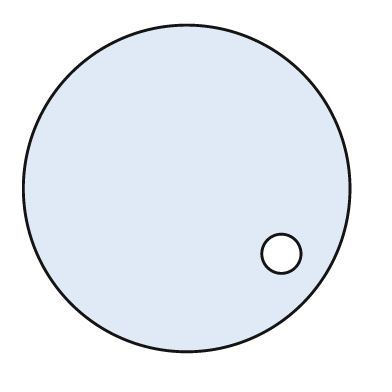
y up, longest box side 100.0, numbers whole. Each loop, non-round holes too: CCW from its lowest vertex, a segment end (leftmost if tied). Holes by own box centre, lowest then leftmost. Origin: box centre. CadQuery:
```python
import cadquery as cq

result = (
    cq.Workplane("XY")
    .moveTo(0.0, 0.0)
    .circle(50.0)
    .moveTo(29.0, -20.0)
    .circle(6.0)
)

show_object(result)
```